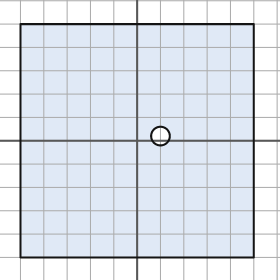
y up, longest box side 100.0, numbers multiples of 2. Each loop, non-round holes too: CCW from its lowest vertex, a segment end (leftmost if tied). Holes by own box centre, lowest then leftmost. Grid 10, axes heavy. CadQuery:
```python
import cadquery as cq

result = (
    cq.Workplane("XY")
    .moveTo(-50.0, -50.0)
    .lineTo(50.0, -50.0)
    .lineTo(50.0, 50.0)
    .lineTo(-50.0, 50.0)
    .close()
    .moveTo(10.0, 2.0)
    .circle(4.0)
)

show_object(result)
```